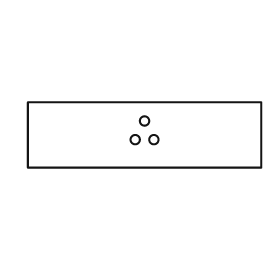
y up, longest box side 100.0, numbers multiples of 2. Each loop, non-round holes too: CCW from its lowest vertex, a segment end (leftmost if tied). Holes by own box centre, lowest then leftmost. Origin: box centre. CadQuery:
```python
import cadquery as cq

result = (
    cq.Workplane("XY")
    .moveTo(-50.0, -14.0)
    .lineTo(50.0, -14.0)
    .lineTo(50.0, 14.0)
    .lineTo(-50.0, 14.0)
    .close()
    .moveTo(-4.0, -2.0)
    .circle(2.0)
    .moveTo(4.0, -2.0)
    .circle(2.0)
    .moveTo(0.0, 6.0)
    .circle(2.0)
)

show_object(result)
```